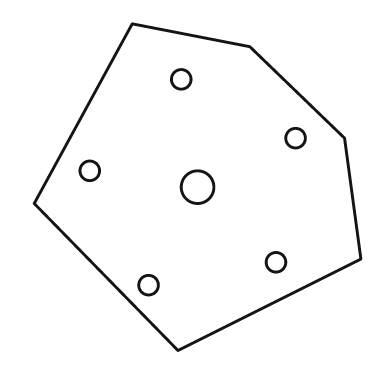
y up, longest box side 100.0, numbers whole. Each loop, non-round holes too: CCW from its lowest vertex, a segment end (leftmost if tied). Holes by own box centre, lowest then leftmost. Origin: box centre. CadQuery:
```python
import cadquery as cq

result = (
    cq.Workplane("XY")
    .moveTo(-6.0, -50.0)
    .lineTo(50.0, -22.0)
    .lineTo(45.0, 15.0)
    .lineTo(16.0, 43.0)
    .lineTo(-20.0, 50.0)
    .lineTo(-50.0, -5.0)
    .close()
    .moveTo(-15.0, -30.0)
    .circle(3.0)
    .moveTo(24.0, -23.0)
    .circle(3.0)
    .moveTo(0.0, 0.0)
    .circle(5.0)
    .moveTo(-33.0, 5.0)
    .circle(3.0)
    .moveTo(30.0, 15.0)
    .circle(3.0)
    .moveTo(-5.0, 33.0)
    .circle(3.0)
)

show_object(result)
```